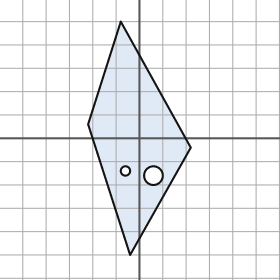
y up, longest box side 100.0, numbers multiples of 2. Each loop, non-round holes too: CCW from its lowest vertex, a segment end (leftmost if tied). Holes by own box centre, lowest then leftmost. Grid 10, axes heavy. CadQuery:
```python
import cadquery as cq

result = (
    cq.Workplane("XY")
    .moveTo(-4.0, -50.0)
    .lineTo(22.0, -4.0)
    .lineTo(-8.0, 50.0)
    .lineTo(-22.0, 6.0)
    .close()
    .moveTo(6.0, -16.0)
    .circle(4.0)
    .moveTo(-6.0, -14.0)
    .circle(2.0)
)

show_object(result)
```